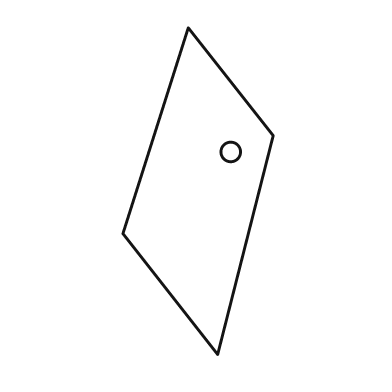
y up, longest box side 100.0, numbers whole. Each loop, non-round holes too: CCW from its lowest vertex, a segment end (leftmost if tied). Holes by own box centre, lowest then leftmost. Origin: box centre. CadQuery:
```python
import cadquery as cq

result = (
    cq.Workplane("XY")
    .moveTo(6.0, -50.0)
    .lineTo(23.0, 17.0)
    .lineTo(-3.0, 50.0)
    .lineTo(-23.0, -13.0)
    .close()
    .moveTo(10.0, 12.0)
    .circle(3.0)
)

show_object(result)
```